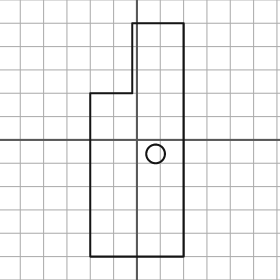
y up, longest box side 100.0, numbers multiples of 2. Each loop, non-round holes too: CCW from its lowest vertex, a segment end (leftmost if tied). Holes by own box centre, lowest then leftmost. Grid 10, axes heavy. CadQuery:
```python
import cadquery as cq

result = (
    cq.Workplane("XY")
    .moveTo(-20.0, -50.0)
    .lineTo(20.0, -50.0)
    .lineTo(20.0, 50.0)
    .lineTo(-2.0, 50.0)
    .lineTo(-2.0, 20.0)
    .lineTo(-20.0, 20.0)
    .close()
    .moveTo(8.0, -6.0)
    .circle(4.0)
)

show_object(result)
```